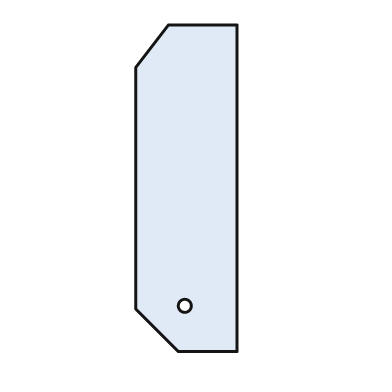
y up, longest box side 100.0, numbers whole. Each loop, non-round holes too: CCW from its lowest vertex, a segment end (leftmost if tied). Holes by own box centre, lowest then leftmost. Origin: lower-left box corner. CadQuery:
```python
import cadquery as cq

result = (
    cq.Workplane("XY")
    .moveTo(13.0, 0.0)
    .lineTo(31.0, 0.0)
    .lineTo(31.0, 100.0)
    .lineTo(10.0, 100.0)
    .lineTo(0.0, 87.0)
    .lineTo(0.0, 13.0)
    .close()
    .moveTo(15.0, 14.0)
    .circle(2.0)
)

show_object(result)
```